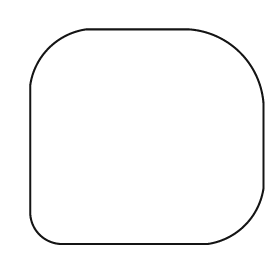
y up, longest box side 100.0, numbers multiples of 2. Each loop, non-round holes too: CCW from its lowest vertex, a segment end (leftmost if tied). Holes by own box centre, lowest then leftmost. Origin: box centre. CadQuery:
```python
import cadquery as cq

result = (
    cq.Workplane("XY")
    .moveTo(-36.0, -46.0)
    .lineTo(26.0, -46.0)
    .threePointArc((42.0, -38.0), (50.0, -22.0))
    .lineTo(50.0, 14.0)
    .threePointArc((40.0, 36.0), (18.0, 46.0))
    .lineTo(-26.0, 46.0)
    .threePointArc((-42.0, 38.0), (-50.0, 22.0))
    .lineTo(-50.0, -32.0)
    .threePointArc((-46.0, -42.0), (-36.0, -46.0))
    .close()
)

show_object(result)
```